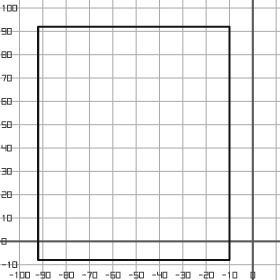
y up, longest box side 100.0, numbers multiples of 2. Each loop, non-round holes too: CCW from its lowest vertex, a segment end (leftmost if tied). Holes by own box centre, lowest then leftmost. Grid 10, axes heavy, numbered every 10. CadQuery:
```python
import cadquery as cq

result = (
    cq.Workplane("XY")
    .moveTo(-92.0, -8.0)
    .lineTo(-10.0, -8.0)
    .lineTo(-10.0, 92.0)
    .lineTo(-92.0, 92.0)
    .close()
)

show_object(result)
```